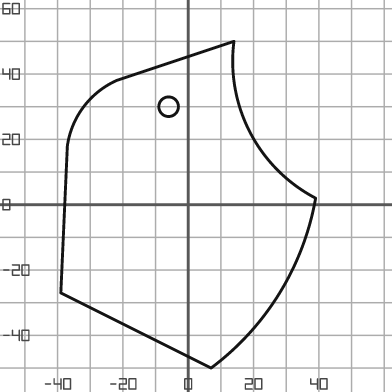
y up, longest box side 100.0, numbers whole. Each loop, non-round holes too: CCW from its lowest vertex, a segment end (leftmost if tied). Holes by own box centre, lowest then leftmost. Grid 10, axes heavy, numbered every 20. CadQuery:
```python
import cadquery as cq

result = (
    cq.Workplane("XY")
    .moveTo(7.0, -50.0)
    .threePointArc((28.0, -27.0), (39.0, 2.0))
    .threePointArc((19.0, 22.0), (14.0, 50.0))
    .lineTo(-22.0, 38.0)
    .threePointArc((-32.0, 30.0), (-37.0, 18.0))
    .lineTo(-39.0, -27.0)
    .close()
    .moveTo(-6.0, 30.0)
    .circle(3.0)
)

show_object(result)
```